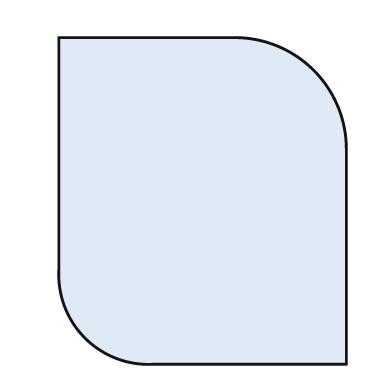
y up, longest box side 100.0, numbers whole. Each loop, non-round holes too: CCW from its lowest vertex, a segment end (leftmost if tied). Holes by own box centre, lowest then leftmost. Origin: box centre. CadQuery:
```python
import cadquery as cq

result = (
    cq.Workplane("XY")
    .moveTo(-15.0, -50.0)
    .lineTo(44.0, -50.0)
    .lineTo(44.0, 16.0)
    .threePointArc((34.0, 40.0), (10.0, 50.0))
    .lineTo(-44.0, 50.0)
    .lineTo(-44.0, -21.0)
    .threePointArc((-36.0, -42.0), (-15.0, -50.0))
    .close()
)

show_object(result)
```